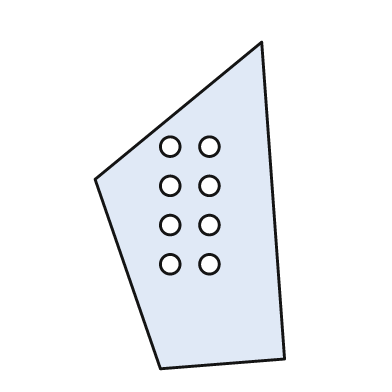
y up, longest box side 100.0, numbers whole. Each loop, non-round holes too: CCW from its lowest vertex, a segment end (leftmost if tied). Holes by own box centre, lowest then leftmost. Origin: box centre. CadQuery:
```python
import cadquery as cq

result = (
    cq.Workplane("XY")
    .moveTo(-9.0, -50.0)
    .lineTo(29.0, -47.0)
    .lineTo(22.0, 50.0)
    .lineTo(-29.0, 8.0)
    .close()
    .moveTo(-6.0, -18.0)
    .circle(3.0)
    .moveTo(6.0, -18.0)
    .circle(3.0)
    .moveTo(-6.0, -6.0)
    .circle(3.0)
    .moveTo(6.0, -6.0)
    .circle(3.0)
    .moveTo(-6.0, 6.0)
    .circle(3.0)
    .moveTo(6.0, 6.0)
    .circle(3.0)
    .moveTo(-6.0, 18.0)
    .circle(3.0)
    .moveTo(6.0, 18.0)
    .circle(3.0)
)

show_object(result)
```